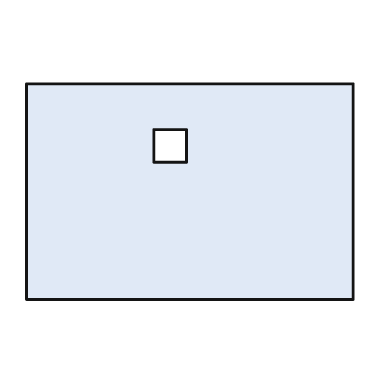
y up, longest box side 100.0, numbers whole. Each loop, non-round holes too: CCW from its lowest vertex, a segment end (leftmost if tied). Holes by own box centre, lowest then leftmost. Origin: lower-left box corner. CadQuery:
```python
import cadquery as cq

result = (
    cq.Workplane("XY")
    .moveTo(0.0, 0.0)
    .lineTo(100.0, 0.0)
    .lineTo(100.0, 66.0)
    .lineTo(0.0, 66.0)
    .close()
    .moveTo(39.0, 42.0)
    .lineTo(49.0, 42.0)
    .lineTo(49.0, 52.0)
    .lineTo(39.0, 52.0)
    .close()
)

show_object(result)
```